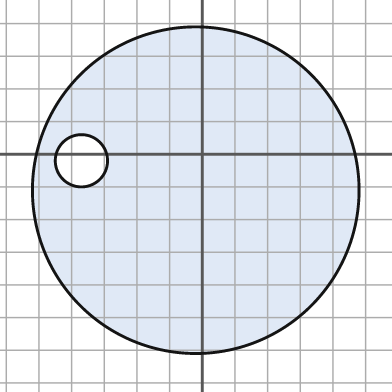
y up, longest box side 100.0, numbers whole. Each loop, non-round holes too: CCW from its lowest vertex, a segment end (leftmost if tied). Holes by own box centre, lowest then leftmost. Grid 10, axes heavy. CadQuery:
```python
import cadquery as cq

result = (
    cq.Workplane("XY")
    .moveTo(-2.0, -11.0)
    .circle(50.0)
    .moveTo(-37.0, -2.0)
    .circle(8.0)
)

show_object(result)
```